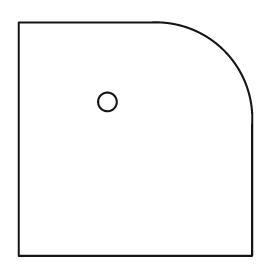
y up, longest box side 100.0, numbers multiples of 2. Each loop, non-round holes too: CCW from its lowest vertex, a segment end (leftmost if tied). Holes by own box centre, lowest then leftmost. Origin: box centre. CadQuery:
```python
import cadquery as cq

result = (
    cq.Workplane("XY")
    .moveTo(-50.0, -50.0)
    .lineTo(50.0, -50.0)
    .lineTo(50.0, 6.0)
    .threePointArc((38.0, 38.0), (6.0, 50.0))
    .lineTo(-50.0, 50.0)
    .close()
    .moveTo(-12.0, 16.0)
    .circle(4.0)
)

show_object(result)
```